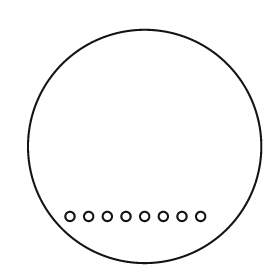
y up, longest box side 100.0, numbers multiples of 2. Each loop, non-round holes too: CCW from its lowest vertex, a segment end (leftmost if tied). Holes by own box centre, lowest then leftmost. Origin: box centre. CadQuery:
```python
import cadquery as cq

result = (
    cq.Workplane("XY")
    .moveTo(0.0, 0.0)
    .circle(50.0)
    .moveTo(-32.0, -30.0)
    .circle(2.0)
    .moveTo(-24.0, -30.0)
    .circle(2.0)
    .moveTo(-16.0, -30.0)
    .circle(2.0)
    .moveTo(-8.0, -30.0)
    .circle(2.0)
    .moveTo(0.0, -30.0)
    .circle(2.0)
    .moveTo(8.0, -30.0)
    .circle(2.0)
    .moveTo(16.0, -30.0)
    .circle(2.0)
    .moveTo(24.0, -30.0)
    .circle(2.0)
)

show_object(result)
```